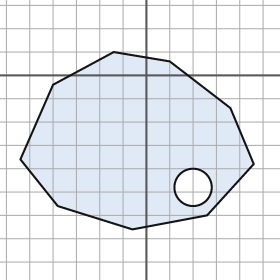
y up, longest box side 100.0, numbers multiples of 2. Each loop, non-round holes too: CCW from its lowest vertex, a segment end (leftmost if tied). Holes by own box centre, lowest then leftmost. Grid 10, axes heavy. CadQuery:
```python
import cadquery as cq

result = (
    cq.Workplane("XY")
    .moveTo(-6.0, -66.0)
    .lineTo(26.0, -60.0)
    .lineTo(46.0, -38.0)
    .lineTo(36.0, -14.0)
    .lineTo(10.0, 6.0)
    .lineTo(-14.0, 10.0)
    .lineTo(-40.0, -4.0)
    .lineTo(-54.0, -36.0)
    .lineTo(-38.0, -56.0)
    .close()
    .moveTo(20.0, -48.0)
    .circle(8.0)
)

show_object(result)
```